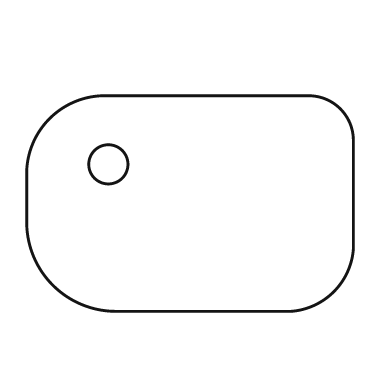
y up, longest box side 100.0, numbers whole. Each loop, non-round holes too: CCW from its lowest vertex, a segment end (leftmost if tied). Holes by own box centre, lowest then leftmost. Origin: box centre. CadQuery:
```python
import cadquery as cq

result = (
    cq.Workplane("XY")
    .moveTo(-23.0, -33.0)
    .lineTo(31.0, -33.0)
    .threePointArc((44.0, -27.0), (50.0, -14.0))
    .lineTo(50.0, 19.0)
    .threePointArc((46.0, 29.0), (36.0, 33.0))
    .lineTo(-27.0, 33.0)
    .threePointArc((-43.0, 26.0), (-50.0, 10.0))
    .lineTo(-50.0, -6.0)
    .threePointArc((-42.0, -25.0), (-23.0, -33.0))
    .close()
    .moveTo(-25.0, 12.0)
    .circle(6.0)
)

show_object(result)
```